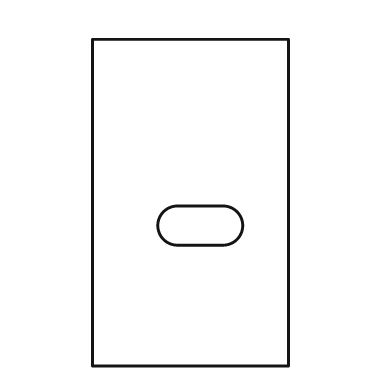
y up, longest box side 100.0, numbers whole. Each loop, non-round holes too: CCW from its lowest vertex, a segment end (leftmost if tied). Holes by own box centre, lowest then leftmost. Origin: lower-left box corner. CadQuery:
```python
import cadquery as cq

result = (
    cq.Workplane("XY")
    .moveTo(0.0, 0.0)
    .lineTo(60.0, 0.0)
    .lineTo(60.0, 100.0)
    .lineTo(0.0, 100.0)
    .close()
    .moveTo(26.0, 37.0)
    .lineTo(40.0, 37.0)
    .threePointArc((46.0, 43.0), (40.0, 49.0))
    .lineTo(26.0, 49.0)
    .threePointArc((20.0, 43.0), (26.0, 37.0))
    .close()
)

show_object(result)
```